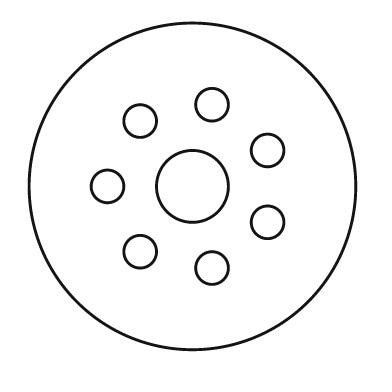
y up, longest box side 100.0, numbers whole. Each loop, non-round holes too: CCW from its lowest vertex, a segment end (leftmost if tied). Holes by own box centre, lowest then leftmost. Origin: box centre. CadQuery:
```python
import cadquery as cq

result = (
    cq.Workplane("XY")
    .moveTo(0.0, 0.0)
    .circle(50.0)
    .moveTo(6.0, -25.0)
    .circle(5.0)
    .moveTo(-16.0, -20.0)
    .circle(5.0)
    .moveTo(23.0, -11.0)
    .circle(5.0)
    .moveTo(-26.0, 0.0)
    .circle(5.0)
    .moveTo(0.0, 0.0)
    .circle(11.0)
    .moveTo(23.0, 11.0)
    .circle(5.0)
    .moveTo(-16.0, 20.0)
    .circle(5.0)
    .moveTo(6.0, 25.0)
    .circle(5.0)
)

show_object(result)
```